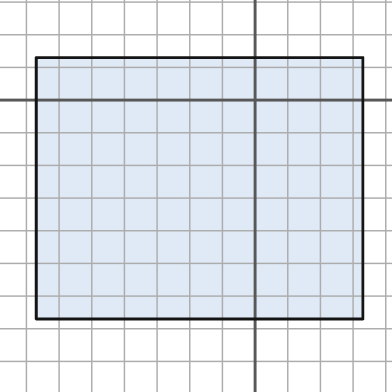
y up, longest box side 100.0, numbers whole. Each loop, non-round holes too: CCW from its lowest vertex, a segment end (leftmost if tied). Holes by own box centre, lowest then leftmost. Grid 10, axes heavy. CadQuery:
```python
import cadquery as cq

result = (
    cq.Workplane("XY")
    .moveTo(-67.0, -67.0)
    .lineTo(33.0, -67.0)
    .lineTo(33.0, 13.0)
    .lineTo(-67.0, 13.0)
    .close()
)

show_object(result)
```